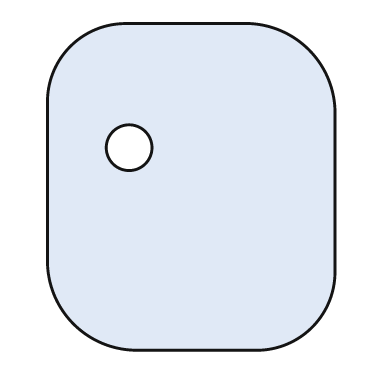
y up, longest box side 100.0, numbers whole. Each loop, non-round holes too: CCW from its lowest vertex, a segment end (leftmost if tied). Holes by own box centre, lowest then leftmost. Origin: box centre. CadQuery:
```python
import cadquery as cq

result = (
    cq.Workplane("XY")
    .moveTo(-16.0, -50.0)
    .lineTo(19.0, -50.0)
    .threePointArc((37.0, -43.0), (44.0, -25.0))
    .lineTo(44.0, 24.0)
    .threePointArc((36.0, 42.0), (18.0, 50.0))
    .lineTo(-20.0, 50.0)
    .threePointArc((-37.0, 43.0), (-44.0, 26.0))
    .lineTo(-44.0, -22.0)
    .threePointArc((-36.0, -42.0), (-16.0, -50.0))
    .close()
    .moveTo(-19.0, 12.0)
    .circle(7.0)
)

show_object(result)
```